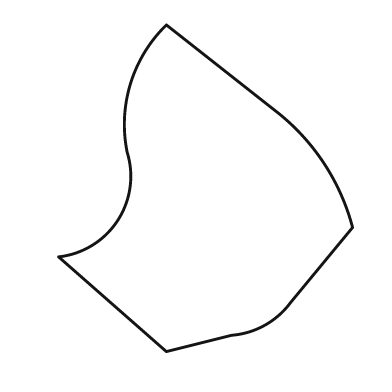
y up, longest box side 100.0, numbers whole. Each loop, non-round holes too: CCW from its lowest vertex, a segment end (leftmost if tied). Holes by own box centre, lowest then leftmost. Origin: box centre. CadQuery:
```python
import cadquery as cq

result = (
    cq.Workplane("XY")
    .moveTo(-12.0, -50.0)
    .lineTo(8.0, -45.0)
    .threePointArc((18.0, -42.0), (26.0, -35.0))
    .lineTo(45.0, -12.0)
    .threePointArc((36.0, 8.0), (21.0, 24.0))
    .lineTo(-12.0, 50.0)
    .threePointArc((-23.0, 32.0), (-24.0, 11.0))
    .threePointArc((-27.0, -10.0), (-45.0, -21.0))
    .close()
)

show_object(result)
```